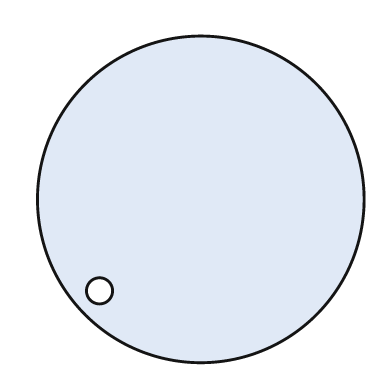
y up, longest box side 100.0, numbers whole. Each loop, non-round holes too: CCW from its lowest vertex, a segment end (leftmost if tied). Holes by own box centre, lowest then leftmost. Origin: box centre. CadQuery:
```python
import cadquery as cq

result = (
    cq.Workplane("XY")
    .moveTo(0.0, 0.0)
    .circle(50.0)
    .moveTo(-31.0, -28.0)
    .circle(4.0)
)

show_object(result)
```